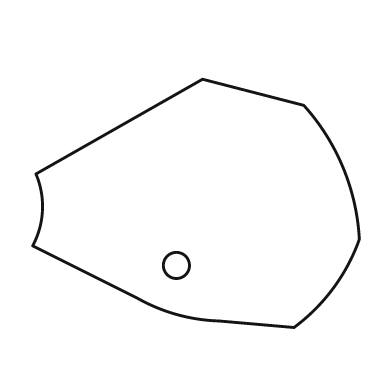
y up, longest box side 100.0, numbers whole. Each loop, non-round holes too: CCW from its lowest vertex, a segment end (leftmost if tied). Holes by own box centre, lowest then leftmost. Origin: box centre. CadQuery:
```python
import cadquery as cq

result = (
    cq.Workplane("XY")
    .moveTo(30.0, -38.0)
    .threePointArc((42.0, -26.0), (50.0, -11.0))
    .threePointArc((45.0, 11.0), (33.0, 30.0))
    .lineTo(2.0, 38.0)
    .lineTo(-49.0, 9.0)
    .threePointArc((-47.0, -2.0), (-50.0, -13.0))
    .lineTo(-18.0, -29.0)
    .threePointArc((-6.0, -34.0), (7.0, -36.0))
    .close()
    .moveTo(-6.0, -19.0)
    .circle(4.0)
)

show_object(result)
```